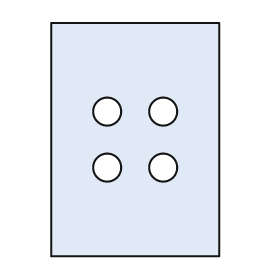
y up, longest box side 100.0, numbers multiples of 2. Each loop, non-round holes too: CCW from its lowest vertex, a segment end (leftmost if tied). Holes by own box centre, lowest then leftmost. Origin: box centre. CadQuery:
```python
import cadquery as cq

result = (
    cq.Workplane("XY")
    .moveTo(-36.0, -50.0)
    .lineTo(36.0, -50.0)
    .lineTo(36.0, 50.0)
    .lineTo(-36.0, 50.0)
    .close()
    .moveTo(-12.0, -12.0)
    .circle(6.0)
    .moveTo(12.0, -12.0)
    .circle(6.0)
    .moveTo(-12.0, 12.0)
    .circle(6.0)
    .moveTo(12.0, 12.0)
    .circle(6.0)
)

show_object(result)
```